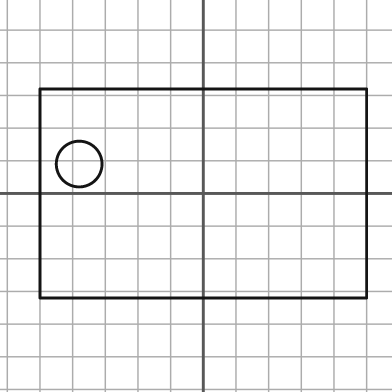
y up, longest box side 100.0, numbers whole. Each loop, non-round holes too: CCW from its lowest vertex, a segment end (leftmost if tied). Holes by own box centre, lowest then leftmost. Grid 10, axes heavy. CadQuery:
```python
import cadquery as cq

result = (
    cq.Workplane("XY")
    .moveTo(-50.0, -32.0)
    .lineTo(50.0, -32.0)
    .lineTo(50.0, 32.0)
    .lineTo(-50.0, 32.0)
    .close()
    .moveTo(-38.0, 9.0)
    .circle(7.0)
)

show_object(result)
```